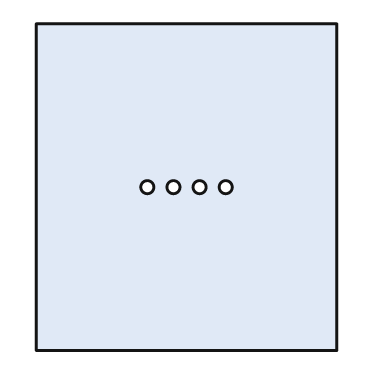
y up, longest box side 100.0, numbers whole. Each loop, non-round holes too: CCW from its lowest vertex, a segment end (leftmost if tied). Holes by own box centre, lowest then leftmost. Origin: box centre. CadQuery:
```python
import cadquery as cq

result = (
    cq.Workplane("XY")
    .moveTo(-46.0, -50.0)
    .lineTo(46.0, -50.0)
    .lineTo(46.0, 50.0)
    .lineTo(-46.0, 50.0)
    .close()
    .moveTo(-12.0, 0.0)
    .circle(2.0)
    .moveTo(-4.0, 0.0)
    .circle(2.0)
    .moveTo(4.0, 0.0)
    .circle(2.0)
    .moveTo(12.0, 0.0)
    .circle(2.0)
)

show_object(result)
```